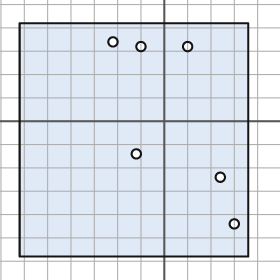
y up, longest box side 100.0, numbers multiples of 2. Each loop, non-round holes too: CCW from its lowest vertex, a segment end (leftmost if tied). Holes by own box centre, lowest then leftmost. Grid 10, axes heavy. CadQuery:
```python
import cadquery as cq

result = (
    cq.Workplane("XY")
    .moveTo(-62.0, -58.0)
    .lineTo(36.0, -58.0)
    .lineTo(36.0, 42.0)
    .lineTo(-62.0, 42.0)
    .close()
    .moveTo(30.0, -44.0)
    .circle(2.0)
    .moveTo(24.0, -24.0)
    .circle(2.0)
    .moveTo(-12.0, -14.0)
    .circle(2.0)
    .moveTo(-10.0, 32.0)
    .circle(2.0)
    .moveTo(10.0, 32.0)
    .circle(2.0)
    .moveTo(-22.0, 34.0)
    .circle(2.0)
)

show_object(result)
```